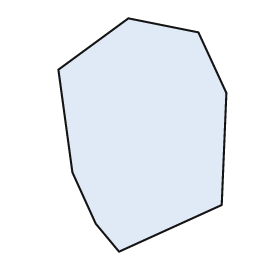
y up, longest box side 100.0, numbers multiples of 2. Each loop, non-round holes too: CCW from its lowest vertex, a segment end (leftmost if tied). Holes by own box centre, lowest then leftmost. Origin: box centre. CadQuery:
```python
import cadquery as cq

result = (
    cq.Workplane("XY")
    .moveTo(-10.0, -50.0)
    .lineTo(34.0, -30.0)
    .lineTo(36.0, 18.0)
    .lineTo(24.0, 44.0)
    .lineTo(-6.0, 50.0)
    .lineTo(-36.0, 28.0)
    .lineTo(-30.0, -16.0)
    .lineTo(-20.0, -38.0)
    .close()
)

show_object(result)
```